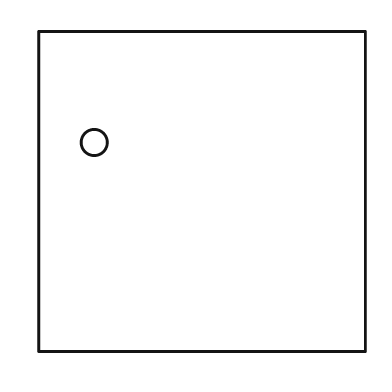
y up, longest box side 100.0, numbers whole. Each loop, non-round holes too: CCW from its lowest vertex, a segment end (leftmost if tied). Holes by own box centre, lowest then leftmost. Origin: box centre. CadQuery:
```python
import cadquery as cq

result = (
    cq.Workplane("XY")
    .moveTo(-50.0, -49.0)
    .lineTo(50.0, -49.0)
    .lineTo(50.0, 49.0)
    .lineTo(-50.0, 49.0)
    .close()
    .moveTo(-33.0, 15.0)
    .circle(4.0)
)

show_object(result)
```